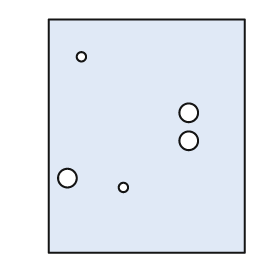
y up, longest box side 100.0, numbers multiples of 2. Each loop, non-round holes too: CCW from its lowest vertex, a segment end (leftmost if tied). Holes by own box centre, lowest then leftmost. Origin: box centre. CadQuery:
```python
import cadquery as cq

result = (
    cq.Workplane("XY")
    .moveTo(-42.0, -50.0)
    .lineTo(42.0, -50.0)
    .lineTo(42.0, 50.0)
    .lineTo(-42.0, 50.0)
    .close()
    .moveTo(-10.0, -22.0)
    .circle(2.0)
    .moveTo(-34.0, -18.0)
    .circle(4.0)
    .moveTo(18.0, -2.0)
    .circle(4.0)
    .moveTo(18.0, 10.0)
    .circle(4.0)
    .moveTo(-28.0, 34.0)
    .circle(2.0)
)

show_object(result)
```